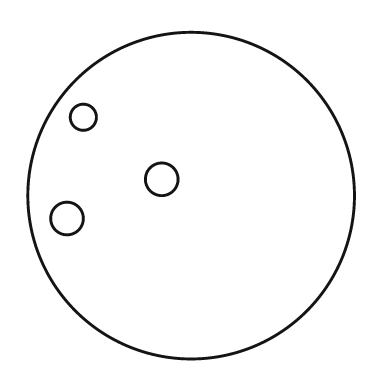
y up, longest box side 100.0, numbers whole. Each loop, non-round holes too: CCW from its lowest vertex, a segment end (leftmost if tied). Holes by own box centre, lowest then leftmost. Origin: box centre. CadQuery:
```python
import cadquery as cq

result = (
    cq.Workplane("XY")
    .moveTo(0.0, 0.0)
    .circle(50.0)
    .moveTo(-38.0, -7.0)
    .circle(5.0)
    .moveTo(-9.0, 5.0)
    .circle(5.0)
    .moveTo(-33.0, 24.0)
    .circle(4.0)
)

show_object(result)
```